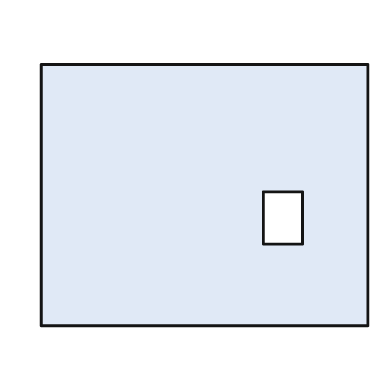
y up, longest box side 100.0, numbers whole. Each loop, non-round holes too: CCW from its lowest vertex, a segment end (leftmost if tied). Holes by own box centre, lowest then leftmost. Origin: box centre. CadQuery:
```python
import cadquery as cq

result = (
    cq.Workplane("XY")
    .moveTo(-50.0, -40.0)
    .lineTo(50.0, -40.0)
    .lineTo(50.0, 40.0)
    .lineTo(-50.0, 40.0)
    .close()
    .moveTo(18.0, -15.0)
    .lineTo(30.0, -15.0)
    .lineTo(30.0, 1.0)
    .lineTo(18.0, 1.0)
    .close()
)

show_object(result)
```